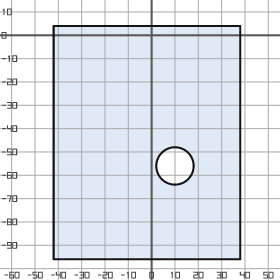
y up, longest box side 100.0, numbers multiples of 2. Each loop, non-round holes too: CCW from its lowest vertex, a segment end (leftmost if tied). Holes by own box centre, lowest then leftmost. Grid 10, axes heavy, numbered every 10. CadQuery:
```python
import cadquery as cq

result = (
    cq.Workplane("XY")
    .moveTo(-42.0, -96.0)
    .lineTo(38.0, -96.0)
    .lineTo(38.0, 4.0)
    .lineTo(-42.0, 4.0)
    .close()
    .moveTo(10.0, -56.0)
    .circle(8.0)
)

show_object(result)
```